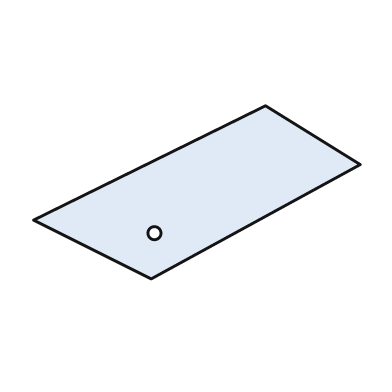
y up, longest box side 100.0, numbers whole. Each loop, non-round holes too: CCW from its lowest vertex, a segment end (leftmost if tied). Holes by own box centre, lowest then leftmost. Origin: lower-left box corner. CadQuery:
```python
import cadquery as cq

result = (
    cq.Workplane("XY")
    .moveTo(36.0, 0.0)
    .lineTo(100.0, 35.0)
    .lineTo(71.0, 53.0)
    .lineTo(0.0, 18.0)
    .close()
    .moveTo(37.0, 14.0)
    .circle(2.0)
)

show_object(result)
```